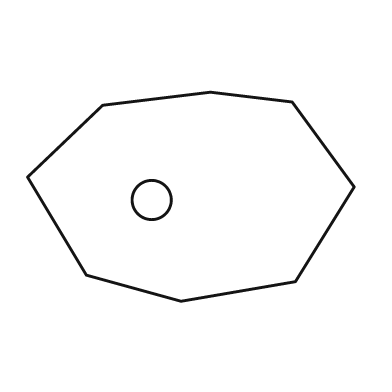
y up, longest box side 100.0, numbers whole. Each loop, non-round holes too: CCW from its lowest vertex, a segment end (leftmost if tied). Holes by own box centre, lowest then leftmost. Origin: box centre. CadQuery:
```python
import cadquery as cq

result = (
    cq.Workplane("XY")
    .moveTo(-3.0, -32.0)
    .lineTo(32.0, -26.0)
    .lineTo(50.0, 3.0)
    .lineTo(31.0, 29.0)
    .lineTo(6.0, 32.0)
    .lineTo(-27.0, 28.0)
    .lineTo(-50.0, 6.0)
    .lineTo(-32.0, -24.0)
    .close()
    .moveTo(-12.0, -1.0)
    .circle(6.0)
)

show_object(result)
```